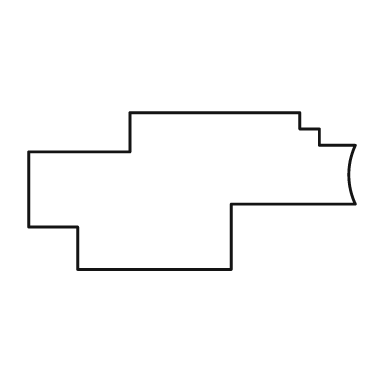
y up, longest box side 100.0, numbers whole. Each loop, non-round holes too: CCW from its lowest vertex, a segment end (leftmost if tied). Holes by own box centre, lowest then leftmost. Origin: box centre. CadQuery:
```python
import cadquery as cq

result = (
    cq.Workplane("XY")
    .moveTo(-35.0, -24.0)
    .lineTo(12.0, -24.0)
    .lineTo(12.0, -4.0)
    .lineTo(50.0, -4.0)
    .threePointArc((48.0, 5.0), (50.0, 14.0))
    .lineTo(39.0, 14.0)
    .lineTo(39.0, 19.0)
    .lineTo(33.0, 19.0)
    .lineTo(33.0, 24.0)
    .lineTo(-19.0, 24.0)
    .lineTo(-19.0, 12.0)
    .lineTo(-50.0, 12.0)
    .lineTo(-50.0, -11.0)
    .lineTo(-35.0, -11.0)
    .close()
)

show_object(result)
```